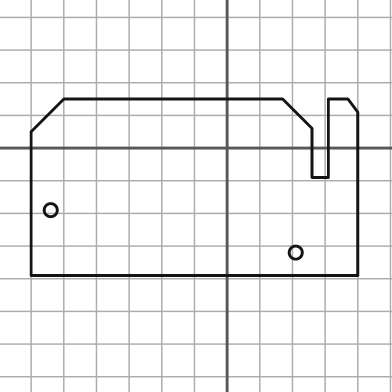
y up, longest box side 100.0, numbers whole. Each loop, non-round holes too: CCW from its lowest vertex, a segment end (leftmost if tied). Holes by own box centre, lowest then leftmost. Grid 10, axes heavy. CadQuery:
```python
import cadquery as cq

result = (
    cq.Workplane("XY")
    .moveTo(-60.0, -39.0)
    .lineTo(40.0, -39.0)
    .lineTo(40.0, 11.0)
    .lineTo(37.0, 15.0)
    .lineTo(31.0, 15.0)
    .lineTo(31.0, -9.0)
    .lineTo(26.0, -9.0)
    .lineTo(26.0, 6.0)
    .lineTo(17.0, 15.0)
    .lineTo(-50.0, 15.0)
    .lineTo(-60.0, 5.0)
    .close()
    .moveTo(21.0, -32.0)
    .circle(2.0)
    .moveTo(-54.0, -19.0)
    .circle(2.0)
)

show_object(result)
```